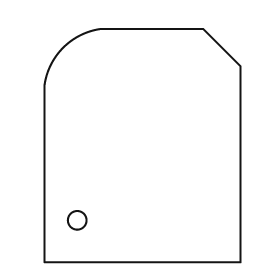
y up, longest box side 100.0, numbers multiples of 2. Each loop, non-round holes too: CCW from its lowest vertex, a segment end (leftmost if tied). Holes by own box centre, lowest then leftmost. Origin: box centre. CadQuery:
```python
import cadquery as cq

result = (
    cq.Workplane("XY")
    .moveTo(-42.0, -50.0)
    .lineTo(42.0, -50.0)
    .lineTo(42.0, 34.0)
    .lineTo(26.0, 50.0)
    .lineTo(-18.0, 50.0)
    .threePointArc((-34.0, 42.0), (-42.0, 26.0))
    .close()
    .moveTo(-28.0, -32.0)
    .circle(4.0)
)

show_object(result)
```